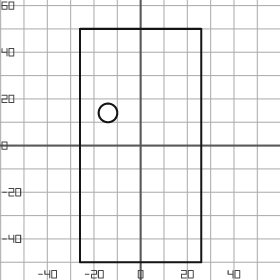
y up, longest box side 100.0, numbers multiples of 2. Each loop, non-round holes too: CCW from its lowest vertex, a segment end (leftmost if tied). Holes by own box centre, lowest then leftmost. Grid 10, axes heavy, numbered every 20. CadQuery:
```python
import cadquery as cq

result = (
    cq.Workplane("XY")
    .moveTo(-26.0, -50.0)
    .lineTo(26.0, -50.0)
    .lineTo(26.0, 50.0)
    .lineTo(-26.0, 50.0)
    .close()
    .moveTo(-14.0, 14.0)
    .circle(4.0)
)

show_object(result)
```